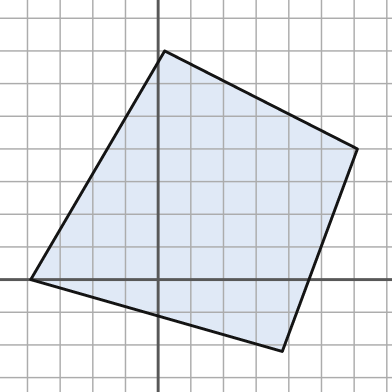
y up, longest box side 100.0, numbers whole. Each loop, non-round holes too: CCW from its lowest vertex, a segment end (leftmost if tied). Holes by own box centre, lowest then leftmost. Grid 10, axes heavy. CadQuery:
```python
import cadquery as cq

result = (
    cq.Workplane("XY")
    .moveTo(38.0, -22.0)
    .lineTo(61.0, 40.0)
    .lineTo(2.0, 70.0)
    .lineTo(-39.0, 0.0)
    .close()
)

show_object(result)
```